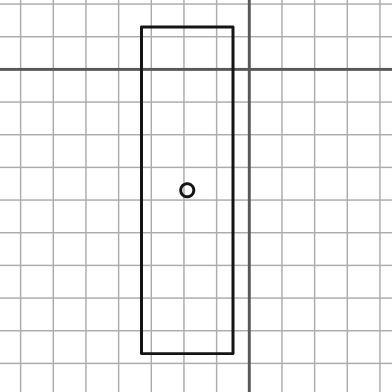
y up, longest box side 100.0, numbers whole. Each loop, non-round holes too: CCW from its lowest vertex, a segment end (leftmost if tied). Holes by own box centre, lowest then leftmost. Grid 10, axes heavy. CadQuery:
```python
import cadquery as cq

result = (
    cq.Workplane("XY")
    .moveTo(-33.0, -87.0)
    .lineTo(-5.0, -87.0)
    .lineTo(-5.0, 13.0)
    .lineTo(-33.0, 13.0)
    .close()
    .moveTo(-19.0, -37.0)
    .circle(2.0)
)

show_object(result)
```